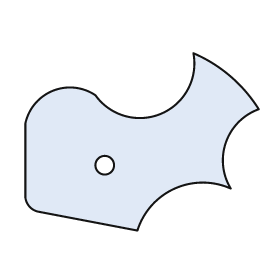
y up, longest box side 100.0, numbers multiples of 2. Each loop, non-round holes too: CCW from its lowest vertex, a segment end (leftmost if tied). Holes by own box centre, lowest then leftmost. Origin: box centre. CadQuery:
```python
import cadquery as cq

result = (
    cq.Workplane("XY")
    .moveTo(-2.0, -38.0)
    .threePointArc((14.0, -20.0), (38.0, -20.0))
    .threePointArc((36.0, 0.0), (50.0, 14.0))
    .threePointArc((38.0, 28.0), (22.0, 38.0))
    .threePointArc((8.0, 12.0), (-20.0, 20.0))
    .threePointArc((-38.0, 22.0), (-50.0, 8.0))
    .lineTo(-50.0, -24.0)
    .threePointArc((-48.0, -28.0), (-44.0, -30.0))
    .close()
    .moveTo(-16.0, -10.0)
    .circle(4.0)
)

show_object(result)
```